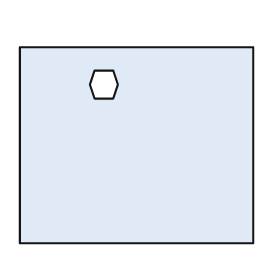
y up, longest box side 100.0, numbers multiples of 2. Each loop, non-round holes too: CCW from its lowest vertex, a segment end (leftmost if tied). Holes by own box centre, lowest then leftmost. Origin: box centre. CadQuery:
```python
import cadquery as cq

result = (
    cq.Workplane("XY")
    .moveTo(-50.0, -42.0)
    .lineTo(50.0, -42.0)
    .lineTo(50.0, 42.0)
    .lineTo(-50.0, 42.0)
    .close()
    .moveTo(-18.0, 20.0)
    .lineTo(-10.0, 20.0)
    .lineTo(-8.0, 26.0)
    .lineTo(-10.0, 32.0)
    .lineTo(-18.0, 32.0)
    .lineTo(-20.0, 26.0)
    .close()
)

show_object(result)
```